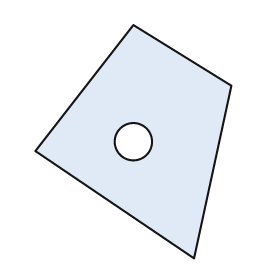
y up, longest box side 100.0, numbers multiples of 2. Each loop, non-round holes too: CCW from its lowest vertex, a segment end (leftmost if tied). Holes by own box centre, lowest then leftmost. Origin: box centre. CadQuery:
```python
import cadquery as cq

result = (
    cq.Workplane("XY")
    .moveTo(26.0, -50.0)
    .lineTo(42.0, 24.0)
    .lineTo(0.0, 50.0)
    .lineTo(-42.0, -4.0)
    .close()
    .moveTo(0.0, 0.0)
    .circle(8.0)
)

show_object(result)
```